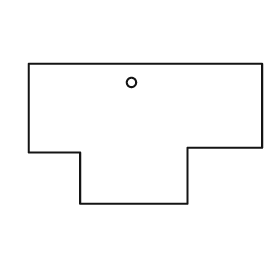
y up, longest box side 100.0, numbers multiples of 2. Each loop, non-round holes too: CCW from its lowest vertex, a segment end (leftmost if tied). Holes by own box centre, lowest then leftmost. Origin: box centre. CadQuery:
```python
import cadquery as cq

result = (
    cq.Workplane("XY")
    .moveTo(-28.0, -30.0)
    .lineTo(18.0, -30.0)
    .lineTo(18.0, -6.0)
    .lineTo(50.0, -6.0)
    .lineTo(50.0, 30.0)
    .lineTo(-50.0, 30.0)
    .lineTo(-50.0, -8.0)
    .lineTo(-28.0, -8.0)
    .close()
    .moveTo(-6.0, 22.0)
    .circle(2.0)
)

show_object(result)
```